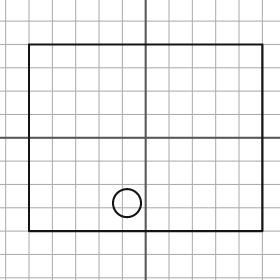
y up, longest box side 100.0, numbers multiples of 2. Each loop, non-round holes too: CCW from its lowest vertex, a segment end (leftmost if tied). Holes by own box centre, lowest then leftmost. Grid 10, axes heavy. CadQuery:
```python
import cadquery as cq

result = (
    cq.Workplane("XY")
    .moveTo(-50.0, -40.0)
    .lineTo(50.0, -40.0)
    .lineTo(50.0, 40.0)
    .lineTo(-50.0, 40.0)
    .close()
    .moveTo(-8.0, -28.0)
    .circle(6.0)
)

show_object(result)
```